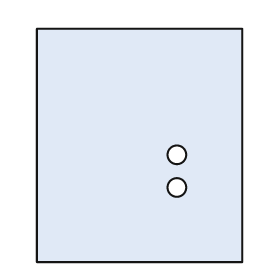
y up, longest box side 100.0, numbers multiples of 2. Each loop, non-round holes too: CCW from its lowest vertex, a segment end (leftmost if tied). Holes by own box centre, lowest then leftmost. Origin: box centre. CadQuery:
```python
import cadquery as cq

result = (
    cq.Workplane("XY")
    .moveTo(-44.0, -50.0)
    .lineTo(44.0, -50.0)
    .lineTo(44.0, 50.0)
    .lineTo(-44.0, 50.0)
    .close()
    .moveTo(16.0, -18.0)
    .circle(4.0)
    .moveTo(16.0, -4.0)
    .circle(4.0)
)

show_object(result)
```